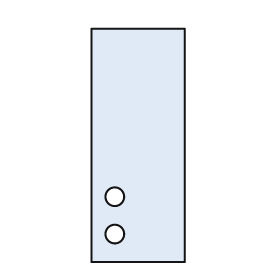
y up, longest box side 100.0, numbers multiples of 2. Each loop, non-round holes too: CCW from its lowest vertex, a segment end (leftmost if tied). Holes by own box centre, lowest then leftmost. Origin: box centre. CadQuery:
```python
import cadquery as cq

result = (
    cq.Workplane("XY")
    .moveTo(-20.0, -50.0)
    .lineTo(20.0, -50.0)
    .lineTo(20.0, 50.0)
    .lineTo(-20.0, 50.0)
    .close()
    .moveTo(-10.0, -38.0)
    .circle(4.0)
    .moveTo(-10.0, -22.0)
    .circle(4.0)
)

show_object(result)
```